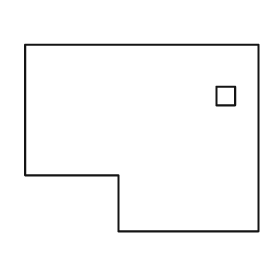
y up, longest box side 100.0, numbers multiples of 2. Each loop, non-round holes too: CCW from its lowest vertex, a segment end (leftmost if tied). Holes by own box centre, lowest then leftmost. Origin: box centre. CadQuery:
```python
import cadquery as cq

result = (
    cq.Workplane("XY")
    .moveTo(-10.0, -40.0)
    .lineTo(50.0, -40.0)
    .lineTo(50.0, 40.0)
    .lineTo(-50.0, 40.0)
    .lineTo(-50.0, -16.0)
    .lineTo(-10.0, -16.0)
    .close()
    .moveTo(32.0, 14.0)
    .lineTo(40.0, 14.0)
    .lineTo(40.0, 22.0)
    .lineTo(32.0, 22.0)
    .close()
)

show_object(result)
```